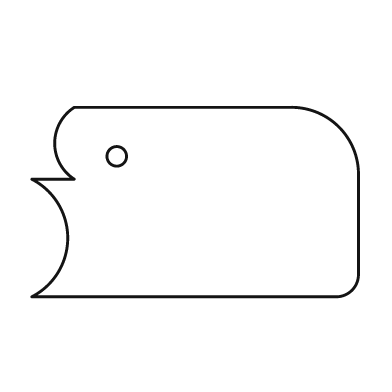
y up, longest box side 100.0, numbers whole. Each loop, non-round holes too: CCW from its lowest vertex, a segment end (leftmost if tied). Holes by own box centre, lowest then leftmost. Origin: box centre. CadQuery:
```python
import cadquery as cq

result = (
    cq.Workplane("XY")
    .moveTo(-50.0, -29.0)
    .lineTo(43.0, -29.0)
    .threePointArc((48.0, -27.0), (50.0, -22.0))
    .lineTo(50.0, 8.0)
    .threePointArc((44.0, 23.0), (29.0, 29.0))
    .lineTo(-37.0, 29.0)
    .threePointArc((-43.0, 18.0), (-37.0, 7.0))
    .lineTo(-50.0, 7.0)
    .threePointArc((-39.0, -11.0), (-50.0, -29.0))
    .close()
    .moveTo(-24.0, 14.0)
    .circle(3.0)
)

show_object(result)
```